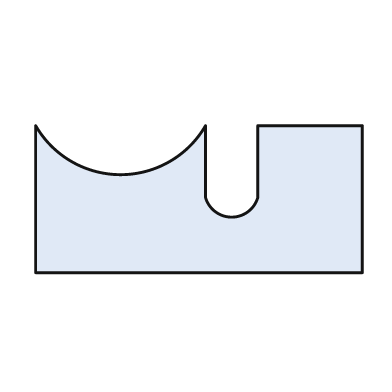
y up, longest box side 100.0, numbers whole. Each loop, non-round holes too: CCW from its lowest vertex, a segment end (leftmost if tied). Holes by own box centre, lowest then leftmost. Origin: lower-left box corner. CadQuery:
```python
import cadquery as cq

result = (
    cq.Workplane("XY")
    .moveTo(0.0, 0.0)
    .lineTo(100.0, 0.0)
    .lineTo(100.0, 45.0)
    .lineTo(68.0, 45.0)
    .lineTo(68.0, 23.0)
    .threePointArc((60.0, 17.0), (52.0, 23.0))
    .lineTo(52.0, 45.0)
    .threePointArc((26.0, 30.0), (0.0, 45.0))
    .close()
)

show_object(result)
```